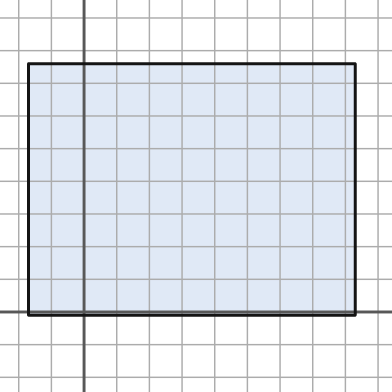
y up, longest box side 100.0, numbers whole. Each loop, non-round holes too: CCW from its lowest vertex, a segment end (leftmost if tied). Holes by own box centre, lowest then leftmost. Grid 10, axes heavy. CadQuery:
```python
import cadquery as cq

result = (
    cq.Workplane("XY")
    .moveTo(-17.0, -1.0)
    .lineTo(83.0, -1.0)
    .lineTo(83.0, 76.0)
    .lineTo(-17.0, 76.0)
    .close()
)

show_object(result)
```